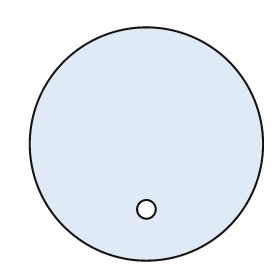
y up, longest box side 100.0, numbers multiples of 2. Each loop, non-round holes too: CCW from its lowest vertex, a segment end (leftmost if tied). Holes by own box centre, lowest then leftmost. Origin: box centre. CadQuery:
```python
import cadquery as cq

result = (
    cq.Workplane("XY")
    .moveTo(0.0, 0.0)
    .circle(50.0)
    .moveTo(0.0, -28.0)
    .circle(4.0)
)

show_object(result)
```